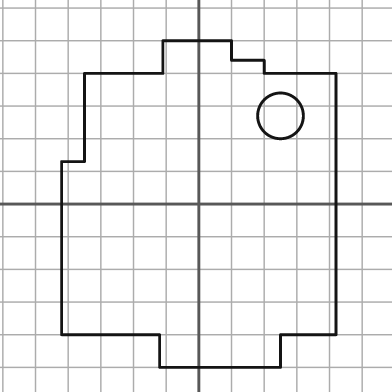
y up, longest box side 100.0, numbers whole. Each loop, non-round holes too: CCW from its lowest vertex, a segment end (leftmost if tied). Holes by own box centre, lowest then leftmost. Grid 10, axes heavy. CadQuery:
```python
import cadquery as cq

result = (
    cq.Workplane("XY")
    .moveTo(-12.0, -50.0)
    .lineTo(25.0, -50.0)
    .lineTo(25.0, -40.0)
    .lineTo(42.0, -40.0)
    .lineTo(42.0, 40.0)
    .lineTo(20.0, 40.0)
    .lineTo(20.0, 44.0)
    .lineTo(10.0, 44.0)
    .lineTo(10.0, 50.0)
    .lineTo(-11.0, 50.0)
    .lineTo(-11.0, 40.0)
    .lineTo(-35.0, 40.0)
    .lineTo(-35.0, 13.0)
    .lineTo(-42.0, 13.0)
    .lineTo(-42.0, -40.0)
    .lineTo(-12.0, -40.0)
    .close()
    .moveTo(25.0, 27.0)
    .circle(7.0)
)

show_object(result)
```